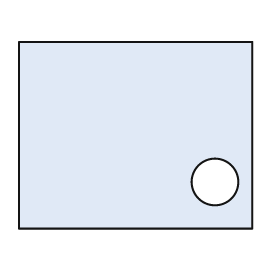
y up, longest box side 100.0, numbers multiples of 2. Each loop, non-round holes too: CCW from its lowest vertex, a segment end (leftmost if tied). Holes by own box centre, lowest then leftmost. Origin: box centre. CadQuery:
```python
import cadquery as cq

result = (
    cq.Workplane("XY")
    .moveTo(-50.0, -40.0)
    .lineTo(50.0, -40.0)
    .lineTo(50.0, 40.0)
    .lineTo(-50.0, 40.0)
    .close()
    .moveTo(34.0, -20.0)
    .circle(10.0)
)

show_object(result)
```